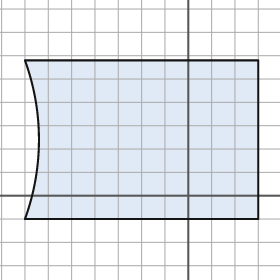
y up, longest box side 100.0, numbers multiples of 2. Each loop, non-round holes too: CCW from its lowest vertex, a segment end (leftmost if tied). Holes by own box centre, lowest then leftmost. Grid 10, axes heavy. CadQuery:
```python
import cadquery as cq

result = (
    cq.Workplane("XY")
    .moveTo(-70.0, -10.0)
    .lineTo(30.0, -10.0)
    .lineTo(30.0, 58.0)
    .lineTo(-70.0, 58.0)
    .threePointArc((-64.0, 24.0), (-70.0, -10.0))
    .close()
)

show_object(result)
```